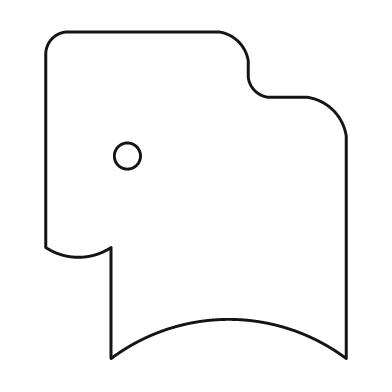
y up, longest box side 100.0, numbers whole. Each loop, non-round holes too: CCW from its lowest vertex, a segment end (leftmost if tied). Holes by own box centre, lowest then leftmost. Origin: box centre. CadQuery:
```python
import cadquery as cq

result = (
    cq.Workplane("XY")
    .moveTo(-26.0, -50.0)
    .threePointArc((10.0, -38.0), (46.0, -50.0))
    .lineTo(46.0, 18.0)
    .threePointArc((42.0, 26.0), (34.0, 30.0))
    .lineTo(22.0, 30.0)
    .threePointArc((18.0, 32.0), (16.0, 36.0))
    .lineTo(16.0, 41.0)
    .threePointArc((13.0, 47.0), (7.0, 50.0))
    .lineTo(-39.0, 50.0)
    .threePointArc((-44.0, 48.0), (-46.0, 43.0))
    .lineTo(-46.0, -16.0)
    .threePointArc((-36.0, -19.0), (-26.0, -16.0))
    .close()
    .moveTo(-21.0, 12.0)
    .circle(4.0)
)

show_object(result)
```